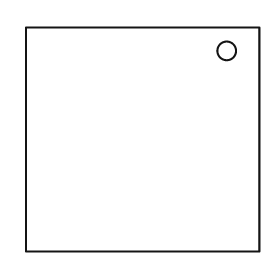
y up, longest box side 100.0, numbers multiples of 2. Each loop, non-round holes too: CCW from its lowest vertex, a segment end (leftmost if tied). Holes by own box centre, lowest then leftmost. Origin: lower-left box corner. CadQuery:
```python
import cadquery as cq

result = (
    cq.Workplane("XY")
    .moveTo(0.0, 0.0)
    .lineTo(100.0, 0.0)
    .lineTo(100.0, 96.0)
    .lineTo(0.0, 96.0)
    .close()
    .moveTo(86.0, 86.0)
    .circle(4.0)
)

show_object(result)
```